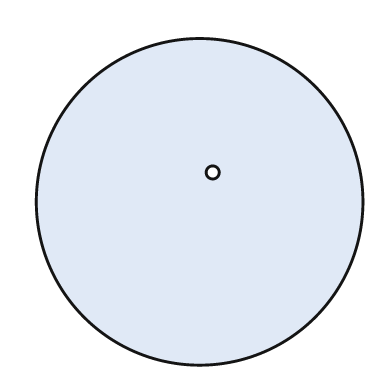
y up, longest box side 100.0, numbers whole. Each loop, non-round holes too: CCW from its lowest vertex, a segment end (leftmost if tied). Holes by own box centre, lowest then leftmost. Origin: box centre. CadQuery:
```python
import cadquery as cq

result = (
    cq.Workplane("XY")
    .moveTo(0.0, 0.0)
    .circle(50.0)
    .moveTo(4.0, 9.0)
    .circle(2.0)
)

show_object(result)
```